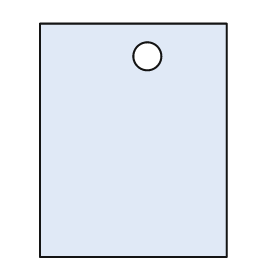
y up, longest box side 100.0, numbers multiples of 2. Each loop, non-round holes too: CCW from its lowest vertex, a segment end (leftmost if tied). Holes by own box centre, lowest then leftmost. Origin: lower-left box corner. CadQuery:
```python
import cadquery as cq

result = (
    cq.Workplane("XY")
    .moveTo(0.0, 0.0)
    .lineTo(80.0, 0.0)
    .lineTo(80.0, 100.0)
    .lineTo(0.0, 100.0)
    .close()
    .moveTo(46.0, 86.0)
    .circle(6.0)
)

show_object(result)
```